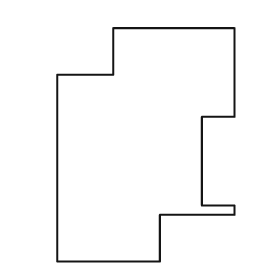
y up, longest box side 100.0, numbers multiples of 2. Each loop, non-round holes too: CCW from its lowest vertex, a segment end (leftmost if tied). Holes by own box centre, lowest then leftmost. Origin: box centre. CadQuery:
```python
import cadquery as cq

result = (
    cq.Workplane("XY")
    .moveTo(-38.0, -50.0)
    .lineTo(6.0, -50.0)
    .lineTo(6.0, -30.0)
    .lineTo(38.0, -30.0)
    .lineTo(38.0, -26.0)
    .lineTo(24.0, -26.0)
    .lineTo(24.0, 12.0)
    .lineTo(38.0, 12.0)
    .lineTo(38.0, 50.0)
    .lineTo(-14.0, 50.0)
    .lineTo(-14.0, 30.0)
    .lineTo(-38.0, 30.0)
    .close()
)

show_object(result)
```